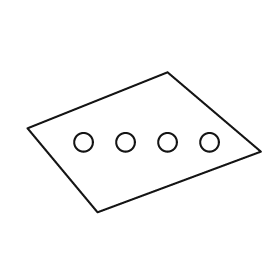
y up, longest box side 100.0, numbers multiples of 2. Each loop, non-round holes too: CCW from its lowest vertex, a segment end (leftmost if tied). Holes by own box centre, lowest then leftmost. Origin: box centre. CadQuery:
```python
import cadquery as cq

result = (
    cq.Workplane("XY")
    .moveTo(-20.0, -30.0)
    .lineTo(50.0, -4.0)
    .lineTo(10.0, 30.0)
    .lineTo(-50.0, 6.0)
    .close()
    .moveTo(-26.0, 0.0)
    .circle(4.0)
    .moveTo(-8.0, 0.0)
    .circle(4.0)
    .moveTo(10.0, 0.0)
    .circle(4.0)
    .moveTo(28.0, 0.0)
    .circle(4.0)
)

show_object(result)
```